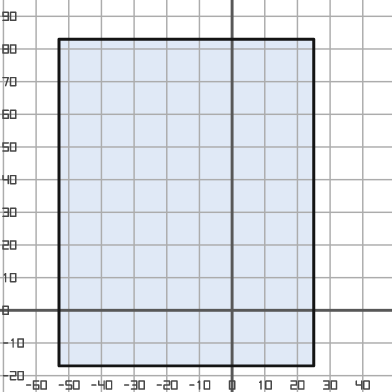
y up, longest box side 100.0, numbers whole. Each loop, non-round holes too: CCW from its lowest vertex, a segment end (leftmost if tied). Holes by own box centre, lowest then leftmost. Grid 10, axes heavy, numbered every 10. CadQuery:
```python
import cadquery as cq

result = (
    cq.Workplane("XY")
    .moveTo(-53.0, -17.0)
    .lineTo(25.0, -17.0)
    .lineTo(25.0, 83.0)
    .lineTo(-53.0, 83.0)
    .close()
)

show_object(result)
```